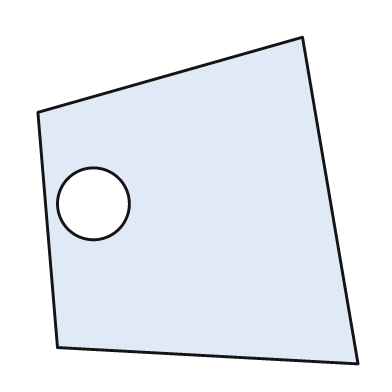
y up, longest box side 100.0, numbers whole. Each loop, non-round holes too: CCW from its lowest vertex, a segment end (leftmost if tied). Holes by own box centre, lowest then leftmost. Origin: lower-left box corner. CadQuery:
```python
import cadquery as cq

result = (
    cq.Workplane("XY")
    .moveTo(98.0, 0.0)
    .lineTo(81.0, 100.0)
    .lineTo(0.0, 77.0)
    .lineTo(6.0, 5.0)
    .close()
    .moveTo(17.0, 49.0)
    .circle(11.0)
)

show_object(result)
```